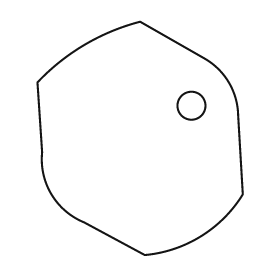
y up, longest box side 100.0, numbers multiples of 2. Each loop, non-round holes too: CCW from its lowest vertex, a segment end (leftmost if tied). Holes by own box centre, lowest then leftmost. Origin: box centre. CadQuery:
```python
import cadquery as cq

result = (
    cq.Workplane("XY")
    .moveTo(2.0, -50.0)
    .threePointArc((26.0, -42.0), (44.0, -24.0))
    .lineTo(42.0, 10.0)
    .threePointArc((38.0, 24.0), (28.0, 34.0))
    .lineTo(0.0, 50.0)
    .threePointArc((-24.0, 40.0), (-44.0, 24.0))
    .lineTo(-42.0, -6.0)
    .threePointArc((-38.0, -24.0), (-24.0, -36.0))
    .close()
    .moveTo(22.0, 14.0)
    .circle(6.0)
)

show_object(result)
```